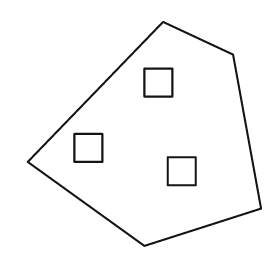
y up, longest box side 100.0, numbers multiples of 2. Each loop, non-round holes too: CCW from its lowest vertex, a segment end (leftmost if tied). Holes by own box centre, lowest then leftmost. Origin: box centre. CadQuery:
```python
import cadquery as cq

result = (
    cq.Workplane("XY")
    .moveTo(0.0, -48.0)
    .lineTo(50.0, -32.0)
    .lineTo(38.0, 34.0)
    .lineTo(8.0, 48.0)
    .lineTo(-50.0, -12.0)
    .close()
    .moveTo(10.0, -22.0)
    .lineTo(22.0, -22.0)
    .lineTo(22.0, -10.0)
    .lineTo(10.0, -10.0)
    .close()
    .moveTo(-30.0, -12.0)
    .lineTo(-18.0, -12.0)
    .lineTo(-18.0, 0.0)
    .lineTo(-30.0, 0.0)
    .close()
    .moveTo(0.0, 16.0)
    .lineTo(12.0, 16.0)
    .lineTo(12.0, 28.0)
    .lineTo(0.0, 28.0)
    .close()
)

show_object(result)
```